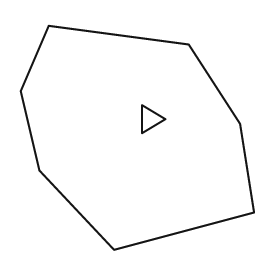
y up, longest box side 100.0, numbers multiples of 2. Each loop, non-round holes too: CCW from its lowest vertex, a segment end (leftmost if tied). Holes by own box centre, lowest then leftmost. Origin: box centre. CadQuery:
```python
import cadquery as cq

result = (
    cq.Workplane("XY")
    .moveTo(-10.0, -48.0)
    .lineTo(50.0, -32.0)
    .lineTo(44.0, 6.0)
    .lineTo(22.0, 40.0)
    .lineTo(-38.0, 48.0)
    .lineTo(-50.0, 20.0)
    .lineTo(-42.0, -14.0)
    .close()
    .moveTo(2.0, 2.0)
    .lineTo(12.0, 8.0)
    .lineTo(2.0, 14.0)
    .close()
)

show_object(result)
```